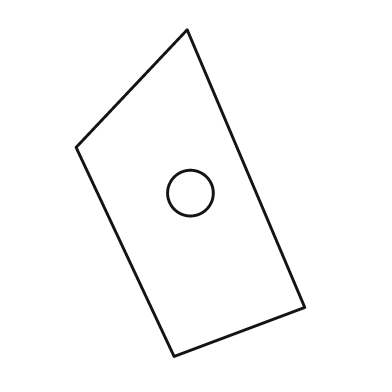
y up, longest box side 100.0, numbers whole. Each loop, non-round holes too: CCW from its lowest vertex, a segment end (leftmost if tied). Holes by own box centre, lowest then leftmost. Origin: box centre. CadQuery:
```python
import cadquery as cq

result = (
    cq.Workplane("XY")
    .moveTo(-5.0, -50.0)
    .lineTo(35.0, -35.0)
    .lineTo(-1.0, 50.0)
    .lineTo(-35.0, 14.0)
    .close()
    .moveTo(0.0, 0.0)
    .circle(7.0)
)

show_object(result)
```